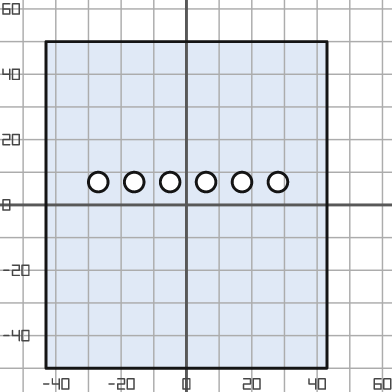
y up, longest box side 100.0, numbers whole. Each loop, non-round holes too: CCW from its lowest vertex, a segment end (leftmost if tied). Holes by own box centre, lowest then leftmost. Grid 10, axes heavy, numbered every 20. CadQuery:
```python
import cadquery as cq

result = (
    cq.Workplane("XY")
    .moveTo(-43.0, -50.0)
    .lineTo(43.0, -50.0)
    .lineTo(43.0, 50.0)
    .lineTo(-43.0, 50.0)
    .close()
    .moveTo(-27.0, 7.0)
    .circle(3.0)
    .moveTo(-16.0, 7.0)
    .circle(3.0)
    .moveTo(-5.0, 7.0)
    .circle(3.0)
    .moveTo(6.0, 7.0)
    .circle(3.0)
    .moveTo(17.0, 7.0)
    .circle(3.0)
    .moveTo(28.0, 7.0)
    .circle(3.0)
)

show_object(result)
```